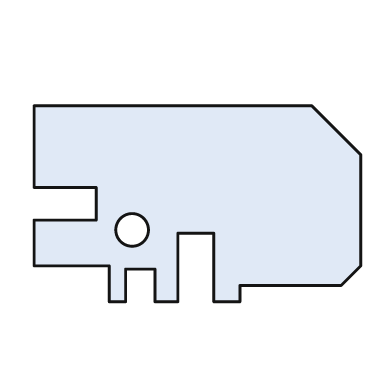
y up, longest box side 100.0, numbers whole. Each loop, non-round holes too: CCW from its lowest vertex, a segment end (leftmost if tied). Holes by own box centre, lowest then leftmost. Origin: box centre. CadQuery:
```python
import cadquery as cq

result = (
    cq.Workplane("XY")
    .moveTo(-27.0, -30.0)
    .lineTo(-22.0, -30.0)
    .lineTo(-22.0, -20.0)
    .lineTo(-13.0, -20.0)
    .lineTo(-13.0, -30.0)
    .lineTo(-6.0, -30.0)
    .lineTo(-6.0, -9.0)
    .lineTo(5.0, -9.0)
    .lineTo(5.0, -30.0)
    .lineTo(13.0, -30.0)
    .lineTo(13.0, -25.0)
    .lineTo(44.0, -25.0)
    .lineTo(50.0, -19.0)
    .lineTo(50.0, 15.0)
    .lineTo(35.0, 30.0)
    .lineTo(-50.0, 30.0)
    .lineTo(-50.0, 5.0)
    .lineTo(-31.0, 5.0)
    .lineTo(-31.0, -5.0)
    .lineTo(-50.0, -5.0)
    .lineTo(-50.0, -19.0)
    .lineTo(-27.0, -19.0)
    .close()
    .moveTo(-20.0, -8.0)
    .circle(5.0)
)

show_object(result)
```